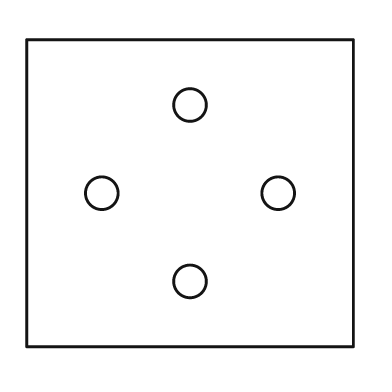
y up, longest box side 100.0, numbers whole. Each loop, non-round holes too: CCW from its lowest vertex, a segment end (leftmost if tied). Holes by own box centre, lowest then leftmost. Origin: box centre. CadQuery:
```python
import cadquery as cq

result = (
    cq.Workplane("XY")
    .moveTo(-50.0, -47.0)
    .lineTo(50.0, -47.0)
    .lineTo(50.0, 47.0)
    .lineTo(-50.0, 47.0)
    .close()
    .moveTo(0.0, -27.0)
    .circle(5.0)
    .moveTo(-27.0, 0.0)
    .circle(5.0)
    .moveTo(27.0, 0.0)
    .circle(5.0)
    .moveTo(0.0, 27.0)
    .circle(5.0)
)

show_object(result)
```